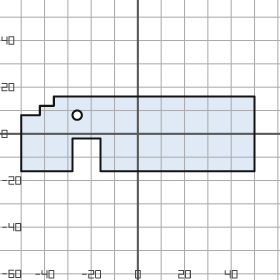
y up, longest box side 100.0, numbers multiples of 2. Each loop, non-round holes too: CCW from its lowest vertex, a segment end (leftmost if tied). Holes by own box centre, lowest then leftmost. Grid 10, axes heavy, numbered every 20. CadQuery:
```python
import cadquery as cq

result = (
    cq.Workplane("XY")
    .moveTo(-50.0, -16.0)
    .lineTo(-28.0, -16.0)
    .lineTo(-28.0, -2.0)
    .lineTo(-16.0, -2.0)
    .lineTo(-16.0, -16.0)
    .lineTo(50.0, -16.0)
    .lineTo(50.0, 16.0)
    .lineTo(-36.0, 16.0)
    .lineTo(-36.0, 12.0)
    .lineTo(-42.0, 12.0)
    .lineTo(-42.0, 8.0)
    .lineTo(-50.0, 8.0)
    .close()
    .moveTo(-26.0, 8.0)
    .circle(2.0)
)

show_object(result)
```